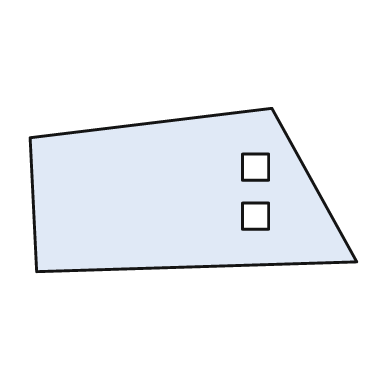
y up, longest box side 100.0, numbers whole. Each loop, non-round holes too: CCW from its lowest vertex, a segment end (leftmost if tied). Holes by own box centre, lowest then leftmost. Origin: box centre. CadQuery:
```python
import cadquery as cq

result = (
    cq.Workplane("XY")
    .moveTo(-48.0, -25.0)
    .lineTo(50.0, -22.0)
    .lineTo(24.0, 25.0)
    .lineTo(-50.0, 16.0)
    .close()
    .moveTo(15.0, -12.0)
    .lineTo(23.0, -12.0)
    .lineTo(23.0, -4.0)
    .lineTo(15.0, -4.0)
    .close()
    .moveTo(15.0, 3.0)
    .lineTo(23.0, 3.0)
    .lineTo(23.0, 11.0)
    .lineTo(15.0, 11.0)
    .close()
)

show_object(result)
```